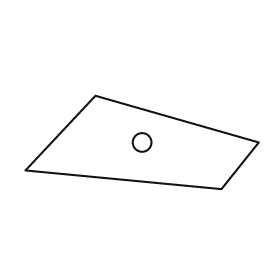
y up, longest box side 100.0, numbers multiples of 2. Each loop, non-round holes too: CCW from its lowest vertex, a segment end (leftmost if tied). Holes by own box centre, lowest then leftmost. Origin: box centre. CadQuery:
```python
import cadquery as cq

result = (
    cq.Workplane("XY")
    .moveTo(34.0, -20.0)
    .lineTo(50.0, 0.0)
    .lineTo(-20.0, 20.0)
    .lineTo(-50.0, -12.0)
    .close()
    .moveTo(0.0, 0.0)
    .circle(4.0)
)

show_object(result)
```